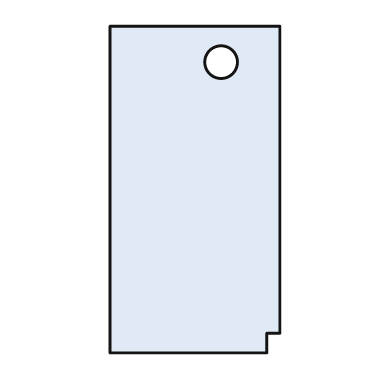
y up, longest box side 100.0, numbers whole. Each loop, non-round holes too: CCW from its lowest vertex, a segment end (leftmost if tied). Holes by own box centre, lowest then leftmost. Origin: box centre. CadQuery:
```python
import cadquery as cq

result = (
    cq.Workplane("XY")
    .moveTo(-26.0, -50.0)
    .lineTo(22.0, -50.0)
    .lineTo(22.0, -44.0)
    .lineTo(26.0, -44.0)
    .lineTo(26.0, 50.0)
    .lineTo(-26.0, 50.0)
    .close()
    .moveTo(8.0, 39.0)
    .circle(5.0)
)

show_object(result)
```